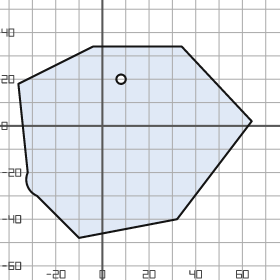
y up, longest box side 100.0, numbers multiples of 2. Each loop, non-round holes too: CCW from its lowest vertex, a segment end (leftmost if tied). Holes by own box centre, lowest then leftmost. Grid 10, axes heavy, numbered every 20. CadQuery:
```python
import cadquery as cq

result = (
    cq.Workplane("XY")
    .moveTo(-10.0, -48.0)
    .lineTo(32.0, -40.0)
    .lineTo(64.0, 2.0)
    .lineTo(34.0, 34.0)
    .lineTo(-4.0, 34.0)
    .lineTo(-36.0, 18.0)
    .lineTo(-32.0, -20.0)
    .threePointArc((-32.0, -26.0), (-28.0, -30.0))
    .close()
    .moveTo(8.0, 20.0)
    .circle(2.0)
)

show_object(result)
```